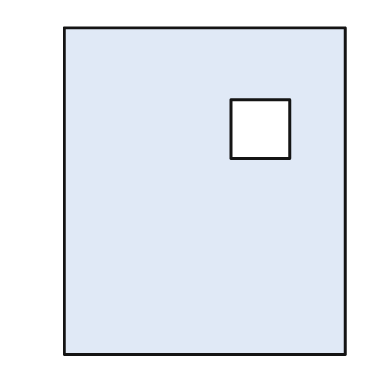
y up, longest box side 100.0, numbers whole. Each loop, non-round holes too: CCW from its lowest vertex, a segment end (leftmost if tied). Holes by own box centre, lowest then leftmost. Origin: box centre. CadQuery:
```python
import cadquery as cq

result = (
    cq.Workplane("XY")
    .moveTo(-43.0, -50.0)
    .lineTo(43.0, -50.0)
    .lineTo(43.0, 50.0)
    .lineTo(-43.0, 50.0)
    .close()
    .moveTo(8.0, 10.0)
    .lineTo(26.0, 10.0)
    .lineTo(26.0, 28.0)
    .lineTo(8.0, 28.0)
    .close()
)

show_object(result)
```